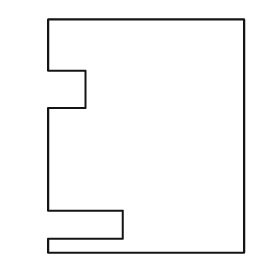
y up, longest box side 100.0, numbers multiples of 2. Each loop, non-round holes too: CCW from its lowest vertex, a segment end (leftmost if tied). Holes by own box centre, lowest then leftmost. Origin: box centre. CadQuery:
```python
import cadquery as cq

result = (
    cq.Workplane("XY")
    .moveTo(-42.0, -50.0)
    .lineTo(42.0, -50.0)
    .lineTo(42.0, 50.0)
    .lineTo(-42.0, 50.0)
    .lineTo(-42.0, 28.0)
    .lineTo(-26.0, 28.0)
    .lineTo(-26.0, 12.0)
    .lineTo(-42.0, 12.0)
    .lineTo(-42.0, -32.0)
    .lineTo(-10.0, -32.0)
    .lineTo(-10.0, -44.0)
    .lineTo(-42.0, -44.0)
    .close()
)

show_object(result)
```